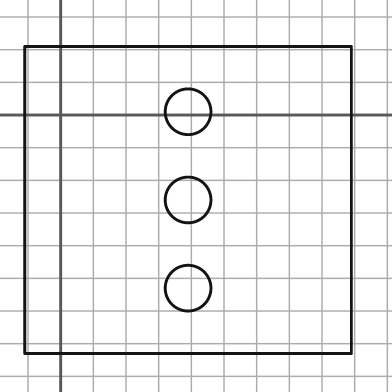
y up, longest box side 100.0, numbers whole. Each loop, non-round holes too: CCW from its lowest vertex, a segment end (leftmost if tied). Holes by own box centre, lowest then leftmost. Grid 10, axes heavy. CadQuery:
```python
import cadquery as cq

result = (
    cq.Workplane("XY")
    .moveTo(-11.0, -73.0)
    .lineTo(89.0, -73.0)
    .lineTo(89.0, 21.0)
    .lineTo(-11.0, 21.0)
    .close()
    .moveTo(39.0, -53.0)
    .circle(7.0)
    .moveTo(39.0, -26.0)
    .circle(7.0)
    .moveTo(39.0, 1.0)
    .circle(7.0)
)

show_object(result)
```